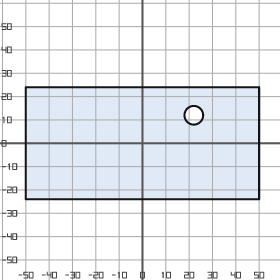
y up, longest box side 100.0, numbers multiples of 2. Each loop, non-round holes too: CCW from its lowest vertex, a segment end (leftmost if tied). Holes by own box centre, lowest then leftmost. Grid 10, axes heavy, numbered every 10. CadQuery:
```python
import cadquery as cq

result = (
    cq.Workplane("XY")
    .moveTo(-50.0, -24.0)
    .lineTo(50.0, -24.0)
    .lineTo(50.0, 24.0)
    .lineTo(-50.0, 24.0)
    .close()
    .moveTo(22.0, 12.0)
    .circle(4.0)
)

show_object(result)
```